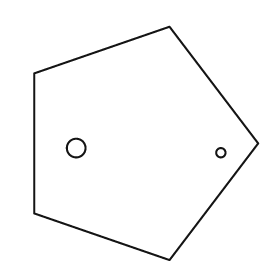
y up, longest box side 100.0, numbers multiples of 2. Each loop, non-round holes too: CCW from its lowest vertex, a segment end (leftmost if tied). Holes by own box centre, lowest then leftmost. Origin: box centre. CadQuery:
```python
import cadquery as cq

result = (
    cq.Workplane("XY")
    .moveTo(10.0, -50.0)
    .lineTo(48.0, 0.0)
    .lineTo(10.0, 50.0)
    .lineTo(-48.0, 30.0)
    .lineTo(-48.0, -30.0)
    .close()
    .moveTo(32.0, -4.0)
    .circle(2.0)
    .moveTo(-30.0, -2.0)
    .circle(4.0)
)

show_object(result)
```